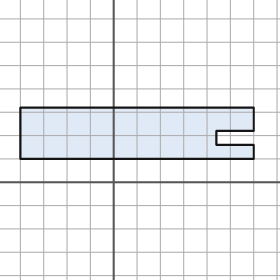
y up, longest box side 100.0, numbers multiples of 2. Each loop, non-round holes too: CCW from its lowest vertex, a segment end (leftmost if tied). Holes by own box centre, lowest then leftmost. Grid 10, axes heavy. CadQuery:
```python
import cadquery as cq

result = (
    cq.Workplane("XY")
    .moveTo(-40.0, 10.0)
    .lineTo(60.0, 10.0)
    .lineTo(60.0, 16.0)
    .lineTo(44.0, 16.0)
    .lineTo(44.0, 22.0)
    .lineTo(60.0, 22.0)
    .lineTo(60.0, 32.0)
    .lineTo(-40.0, 32.0)
    .close()
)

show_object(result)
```